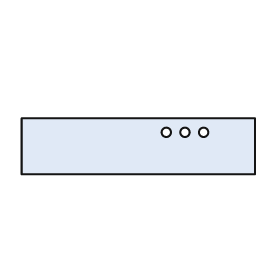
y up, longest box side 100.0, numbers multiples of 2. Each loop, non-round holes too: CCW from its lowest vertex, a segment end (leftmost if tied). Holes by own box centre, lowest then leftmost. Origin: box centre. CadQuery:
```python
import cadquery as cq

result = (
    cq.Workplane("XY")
    .moveTo(-50.0, -12.0)
    .lineTo(50.0, -12.0)
    .lineTo(50.0, 12.0)
    .lineTo(-50.0, 12.0)
    .close()
    .moveTo(12.0, 6.0)
    .circle(2.0)
    .moveTo(20.0, 6.0)
    .circle(2.0)
    .moveTo(28.0, 6.0)
    .circle(2.0)
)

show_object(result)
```